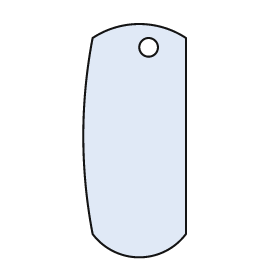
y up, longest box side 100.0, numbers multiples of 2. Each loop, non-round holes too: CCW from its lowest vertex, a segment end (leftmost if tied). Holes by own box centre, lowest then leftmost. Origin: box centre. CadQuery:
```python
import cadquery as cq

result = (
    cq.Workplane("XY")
    .moveTo(-18.0, -40.0)
    .threePointArc((2.0, -50.0), (22.0, -40.0))
    .lineTo(22.0, 44.0)
    .threePointArc((2.0, 50.0), (-18.0, 44.0))
    .threePointArc((-22.0, 2.0), (-18.0, -40.0))
    .close()
    .moveTo(6.0, 40.0)
    .circle(4.0)
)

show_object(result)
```